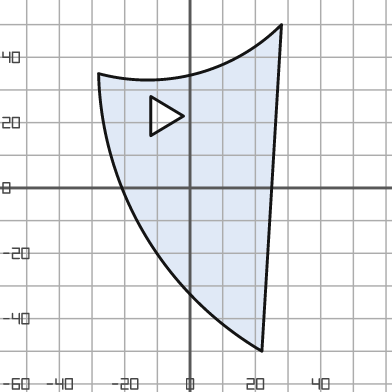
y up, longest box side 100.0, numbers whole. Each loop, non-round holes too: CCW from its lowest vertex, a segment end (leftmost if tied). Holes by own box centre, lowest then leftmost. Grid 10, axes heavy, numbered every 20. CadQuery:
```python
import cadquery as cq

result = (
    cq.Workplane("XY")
    .moveTo(22.0, -50.0)
    .lineTo(28.0, 50.0)
    .threePointArc((2.0, 35.0), (-28.0, 35.0))
    .threePointArc((-14.0, -14.0), (22.0, -50.0))
    .close()
    .moveTo(-12.0, 16.0)
    .lineTo(-2.0, 22.0)
    .lineTo(-12.0, 28.0)
    .close()
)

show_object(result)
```